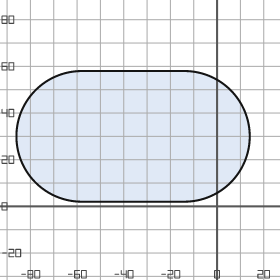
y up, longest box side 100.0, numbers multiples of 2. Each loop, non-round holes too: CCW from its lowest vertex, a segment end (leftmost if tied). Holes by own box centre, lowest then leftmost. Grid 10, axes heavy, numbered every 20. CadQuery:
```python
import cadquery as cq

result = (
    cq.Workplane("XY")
    .moveTo(-58.0, 2.0)
    .lineTo(-14.0, 2.0)
    .threePointArc((14.0, 30.0), (-14.0, 58.0))
    .lineTo(-58.0, 58.0)
    .threePointArc((-86.0, 30.0), (-58.0, 2.0))
    .close()
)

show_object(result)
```